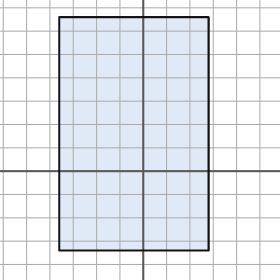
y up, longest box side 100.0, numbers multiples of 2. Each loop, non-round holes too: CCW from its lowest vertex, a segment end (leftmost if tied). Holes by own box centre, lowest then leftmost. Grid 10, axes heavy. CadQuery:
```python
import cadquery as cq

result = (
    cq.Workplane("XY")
    .moveTo(-36.0, -34.0)
    .lineTo(28.0, -34.0)
    .lineTo(28.0, 66.0)
    .lineTo(-36.0, 66.0)
    .close()
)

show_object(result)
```